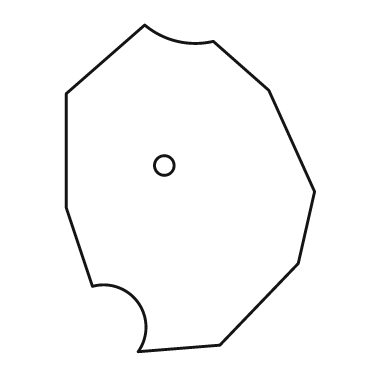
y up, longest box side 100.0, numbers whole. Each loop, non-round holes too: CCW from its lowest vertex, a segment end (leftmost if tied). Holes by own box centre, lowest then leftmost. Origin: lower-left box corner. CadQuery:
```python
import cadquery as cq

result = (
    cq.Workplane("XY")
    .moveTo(22.0, 0.0)
    .lineTo(47.0, 2.0)
    .lineTo(71.0, 27.0)
    .lineTo(76.0, 49.0)
    .lineTo(62.0, 80.0)
    .lineTo(45.0, 95.0)
    .threePointArc((34.0, 95.0), (24.0, 100.0))
    .lineTo(0.0, 79.0)
    .lineTo(0.0, 44.0)
    .lineTo(8.0, 20.0)
    .threePointArc((22.0, 15.0), (22.0, 0.0))
    .close()
    .moveTo(30.0, 57.0)
    .circle(3.0)
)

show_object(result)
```